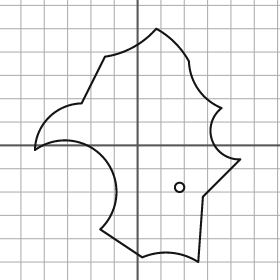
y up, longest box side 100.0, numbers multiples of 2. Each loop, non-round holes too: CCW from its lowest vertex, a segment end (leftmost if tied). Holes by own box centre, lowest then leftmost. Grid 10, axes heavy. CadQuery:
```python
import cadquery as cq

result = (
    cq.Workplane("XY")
    .moveTo(26.0, -50.0)
    .lineTo(28.0, -22.0)
    .lineTo(44.0, -6.0)
    .threePointArc((32.0, 2.0), (36.0, 16.0))
    .threePointArc((26.0, 24.0), (22.0, 36.0))
    .threePointArc((16.0, 44.0), (8.0, 50.0))
    .threePointArc((-2.0, 42.0), (-14.0, 38.0))
    .lineTo(-24.0, 18.0)
    .threePointArc((-38.0, 12.0), (-44.0, -2.0))
    .threePointArc((-14.0, -6.0), (-16.0, -36.0))
    .lineTo(2.0, -48.0)
    .threePointArc((14.0, -46.0), (26.0, -50.0))
    .close()
    .moveTo(18.0, -18.0)
    .circle(2.0)
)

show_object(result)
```